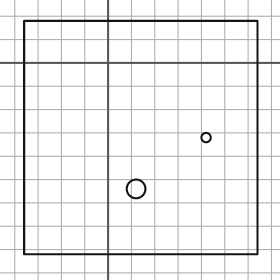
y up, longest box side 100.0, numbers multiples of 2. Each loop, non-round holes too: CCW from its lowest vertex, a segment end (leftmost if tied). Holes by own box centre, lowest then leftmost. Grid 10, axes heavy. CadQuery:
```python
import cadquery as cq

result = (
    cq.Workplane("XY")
    .moveTo(-36.0, -82.0)
    .lineTo(64.0, -82.0)
    .lineTo(64.0, 18.0)
    .lineTo(-36.0, 18.0)
    .close()
    .moveTo(12.0, -54.0)
    .circle(4.0)
    .moveTo(42.0, -32.0)
    .circle(2.0)
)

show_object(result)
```